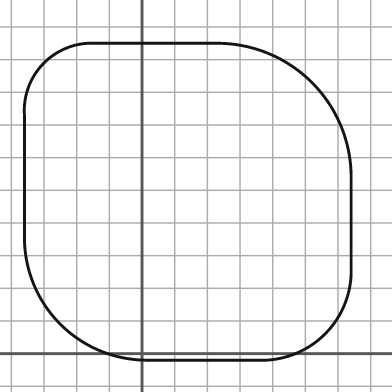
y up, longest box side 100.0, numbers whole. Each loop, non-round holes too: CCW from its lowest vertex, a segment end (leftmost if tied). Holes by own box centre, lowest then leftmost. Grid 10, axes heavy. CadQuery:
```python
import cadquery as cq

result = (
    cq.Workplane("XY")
    .moveTo(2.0, -2.0)
    .lineTo(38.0, -2.0)
    .threePointArc((56.0, 6.0), (64.0, 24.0))
    .lineTo(64.0, 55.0)
    .threePointArc((52.0, 83.0), (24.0, 95.0))
    .lineTo(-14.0, 95.0)
    .threePointArc((-30.0, 89.0), (-36.0, 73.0))
    .lineTo(-36.0, 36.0)
    .threePointArc((-25.0, 9.0), (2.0, -2.0))
    .close()
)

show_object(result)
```